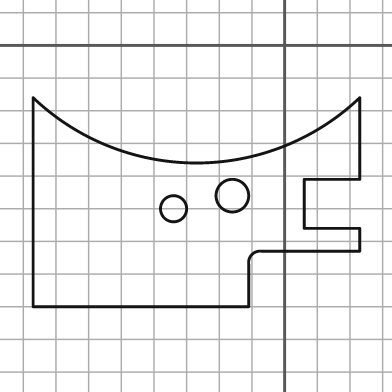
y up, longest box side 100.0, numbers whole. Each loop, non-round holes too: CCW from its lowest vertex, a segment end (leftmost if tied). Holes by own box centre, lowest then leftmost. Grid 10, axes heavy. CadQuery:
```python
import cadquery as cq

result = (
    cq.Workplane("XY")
    .moveTo(-77.0, -80.0)
    .lineTo(-11.0, -80.0)
    .lineTo(-11.0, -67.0)
    .threePointArc((-10.0, -64.0), (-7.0, -63.0))
    .lineTo(23.0, -63.0)
    .lineTo(23.0, -56.0)
    .lineTo(6.0, -56.0)
    .lineTo(6.0, -41.0)
    .lineTo(23.0, -41.0)
    .lineTo(23.0, -16.0)
    .threePointArc((-27.0, -36.0), (-77.0, -16.0))
    .close()
    .moveTo(-34.0, -50.0)
    .circle(4.0)
    .moveTo(-16.0, -46.0)
    .circle(5.0)
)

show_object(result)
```